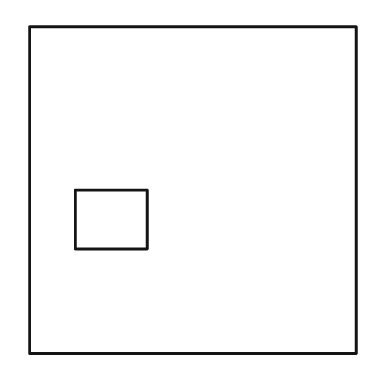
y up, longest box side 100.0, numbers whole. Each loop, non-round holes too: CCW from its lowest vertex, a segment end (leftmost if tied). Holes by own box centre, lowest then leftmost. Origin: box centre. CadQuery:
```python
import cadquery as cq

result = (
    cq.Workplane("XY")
    .moveTo(-50.0, -50.0)
    .lineTo(50.0, -50.0)
    .lineTo(50.0, 50.0)
    .lineTo(-50.0, 50.0)
    .close()
    .moveTo(-36.0, -18.0)
    .lineTo(-14.0, -18.0)
    .lineTo(-14.0, 0.0)
    .lineTo(-36.0, 0.0)
    .close()
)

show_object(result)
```